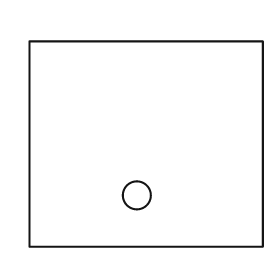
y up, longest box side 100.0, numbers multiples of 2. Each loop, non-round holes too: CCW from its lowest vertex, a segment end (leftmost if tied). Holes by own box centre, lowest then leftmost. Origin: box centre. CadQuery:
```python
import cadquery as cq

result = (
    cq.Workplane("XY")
    .moveTo(-50.0, -44.0)
    .lineTo(50.0, -44.0)
    .lineTo(50.0, 44.0)
    .lineTo(-50.0, 44.0)
    .close()
    .moveTo(-4.0, -22.0)
    .circle(6.0)
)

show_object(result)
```